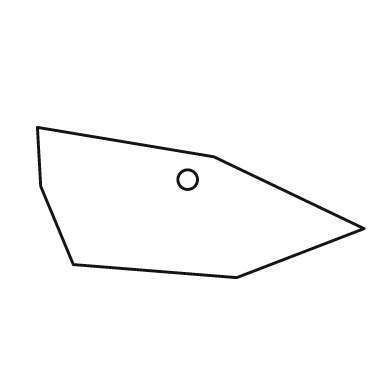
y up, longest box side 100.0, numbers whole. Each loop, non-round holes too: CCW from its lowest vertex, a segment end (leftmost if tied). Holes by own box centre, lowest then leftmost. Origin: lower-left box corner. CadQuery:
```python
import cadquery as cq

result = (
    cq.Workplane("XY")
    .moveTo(61.0, 0.0)
    .lineTo(100.0, 15.0)
    .lineTo(54.0, 37.0)
    .lineTo(0.0, 46.0)
    .lineTo(1.0, 28.0)
    .lineTo(11.0, 4.0)
    .close()
    .moveTo(46.0, 30.0)
    .circle(3.0)
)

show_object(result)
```